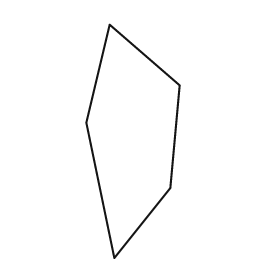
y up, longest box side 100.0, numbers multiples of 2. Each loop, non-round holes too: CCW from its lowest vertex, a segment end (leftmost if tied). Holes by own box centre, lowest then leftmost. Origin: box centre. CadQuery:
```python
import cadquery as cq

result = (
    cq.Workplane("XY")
    .moveTo(-8.0, -50.0)
    .lineTo(16.0, -20.0)
    .lineTo(20.0, 24.0)
    .lineTo(-10.0, 50.0)
    .lineTo(-20.0, 8.0)
    .close()
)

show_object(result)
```